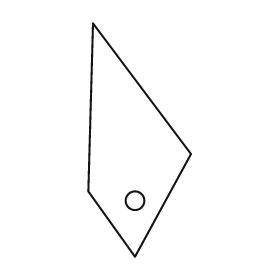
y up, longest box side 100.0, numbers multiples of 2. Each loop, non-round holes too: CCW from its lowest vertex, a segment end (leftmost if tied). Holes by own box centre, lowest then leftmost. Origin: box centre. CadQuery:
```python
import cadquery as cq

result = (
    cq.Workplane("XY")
    .moveTo(-2.0, -50.0)
    .lineTo(22.0, -6.0)
    .lineTo(-20.0, 50.0)
    .lineTo(-22.0, -22.0)
    .close()
    .moveTo(-2.0, -26.0)
    .circle(4.0)
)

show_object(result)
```